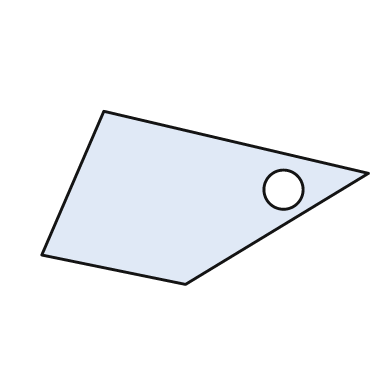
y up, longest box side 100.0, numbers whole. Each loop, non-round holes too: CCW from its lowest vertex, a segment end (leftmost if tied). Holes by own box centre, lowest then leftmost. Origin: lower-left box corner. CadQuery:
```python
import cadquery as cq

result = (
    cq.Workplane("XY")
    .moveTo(44.0, 0.0)
    .lineTo(100.0, 34.0)
    .lineTo(19.0, 53.0)
    .lineTo(0.0, 9.0)
    .close()
    .moveTo(74.0, 29.0)
    .circle(6.0)
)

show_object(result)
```